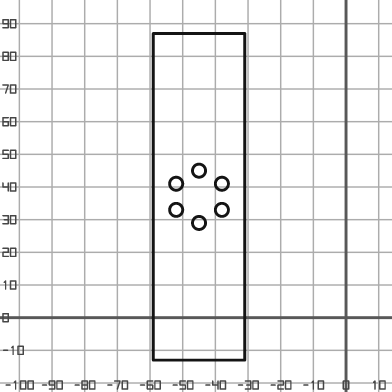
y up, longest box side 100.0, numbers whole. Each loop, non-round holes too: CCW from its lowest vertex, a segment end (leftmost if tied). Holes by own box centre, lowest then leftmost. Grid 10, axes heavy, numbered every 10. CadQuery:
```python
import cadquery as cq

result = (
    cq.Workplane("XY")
    .moveTo(-59.0, -13.0)
    .lineTo(-31.0, -13.0)
    .lineTo(-31.0, 87.0)
    .lineTo(-59.0, 87.0)
    .close()
    .moveTo(-45.0, 29.0)
    .circle(2.0)
    .moveTo(-52.0, 33.0)
    .circle(2.0)
    .moveTo(-38.0, 33.0)
    .circle(2.0)
    .moveTo(-52.0, 41.0)
    .circle(2.0)
    .moveTo(-38.0, 41.0)
    .circle(2.0)
    .moveTo(-45.0, 45.0)
    .circle(2.0)
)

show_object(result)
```